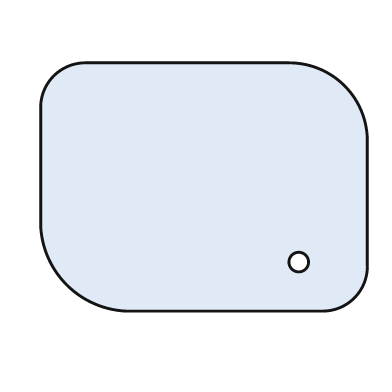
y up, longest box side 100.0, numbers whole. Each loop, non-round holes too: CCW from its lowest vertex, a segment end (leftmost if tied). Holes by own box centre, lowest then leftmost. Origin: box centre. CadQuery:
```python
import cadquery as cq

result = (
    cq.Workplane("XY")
    .moveTo(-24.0, -38.0)
    .lineTo(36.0, -38.0)
    .threePointArc((46.0, -34.0), (50.0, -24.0))
    .lineTo(50.0, 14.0)
    .threePointArc((43.0, 31.0), (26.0, 38.0))
    .lineTo(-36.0, 38.0)
    .threePointArc((-46.0, 34.0), (-50.0, 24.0))
    .lineTo(-50.0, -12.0)
    .threePointArc((-42.0, -30.0), (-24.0, -38.0))
    .close()
    .moveTo(29.0, -23.0)
    .circle(3.0)
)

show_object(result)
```